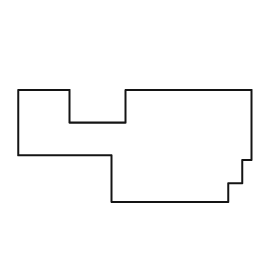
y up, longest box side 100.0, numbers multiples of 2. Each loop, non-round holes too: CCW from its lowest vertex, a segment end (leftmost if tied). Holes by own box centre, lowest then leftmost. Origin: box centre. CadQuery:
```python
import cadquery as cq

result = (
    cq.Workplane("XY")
    .moveTo(-10.0, -24.0)
    .lineTo(40.0, -24.0)
    .lineTo(40.0, -16.0)
    .lineTo(46.0, -16.0)
    .lineTo(46.0, -6.0)
    .lineTo(50.0, -6.0)
    .lineTo(50.0, 24.0)
    .lineTo(-4.0, 24.0)
    .lineTo(-4.0, 10.0)
    .lineTo(-28.0, 10.0)
    .lineTo(-28.0, 24.0)
    .lineTo(-50.0, 24.0)
    .lineTo(-50.0, -4.0)
    .lineTo(-10.0, -4.0)
    .close()
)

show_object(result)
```